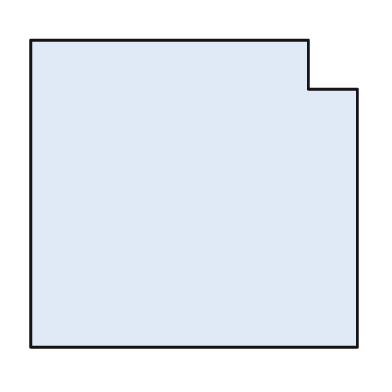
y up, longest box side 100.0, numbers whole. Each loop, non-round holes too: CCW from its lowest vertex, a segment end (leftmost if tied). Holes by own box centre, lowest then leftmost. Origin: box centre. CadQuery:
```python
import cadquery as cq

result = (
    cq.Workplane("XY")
    .moveTo(-50.0, -47.0)
    .lineTo(50.0, -47.0)
    .lineTo(50.0, 32.0)
    .lineTo(35.0, 32.0)
    .lineTo(35.0, 47.0)
    .lineTo(-50.0, 47.0)
    .close()
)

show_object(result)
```